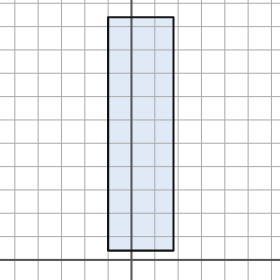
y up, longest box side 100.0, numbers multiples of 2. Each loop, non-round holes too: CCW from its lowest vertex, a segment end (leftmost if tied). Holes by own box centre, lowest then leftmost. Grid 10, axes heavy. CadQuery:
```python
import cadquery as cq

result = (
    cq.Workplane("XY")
    .moveTo(-10.0, 4.0)
    .lineTo(18.0, 4.0)
    .lineTo(18.0, 104.0)
    .lineTo(-10.0, 104.0)
    .close()
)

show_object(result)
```